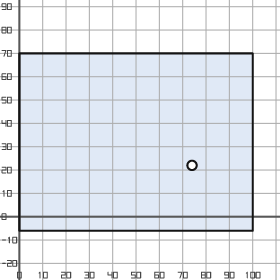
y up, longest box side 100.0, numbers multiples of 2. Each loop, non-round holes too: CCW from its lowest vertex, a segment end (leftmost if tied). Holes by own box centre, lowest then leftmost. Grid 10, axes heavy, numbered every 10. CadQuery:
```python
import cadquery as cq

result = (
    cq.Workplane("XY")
    .moveTo(0.0, -6.0)
    .lineTo(100.0, -6.0)
    .lineTo(100.0, 70.0)
    .lineTo(0.0, 70.0)
    .close()
    .moveTo(74.0, 22.0)
    .circle(2.0)
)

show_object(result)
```